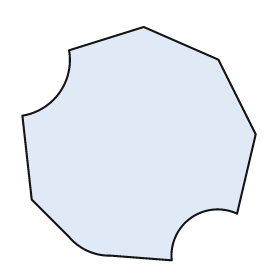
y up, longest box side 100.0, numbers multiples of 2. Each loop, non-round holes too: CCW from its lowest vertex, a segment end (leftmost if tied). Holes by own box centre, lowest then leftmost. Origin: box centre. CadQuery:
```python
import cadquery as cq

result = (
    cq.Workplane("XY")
    .moveTo(14.0, -50.0)
    .threePointArc((22.0, -32.0), (42.0, -30.0))
    .lineTo(50.0, 4.0)
    .lineTo(34.0, 36.0)
    .lineTo(2.0, 50.0)
    .lineTo(-30.0, 40.0)
    .threePointArc((-34.0, 22.0), (-50.0, 12.0))
    .lineTo(-46.0, -24.0)
    .lineTo(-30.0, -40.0)
    .threePointArc((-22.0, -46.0), (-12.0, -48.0))
    .close()
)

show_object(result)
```